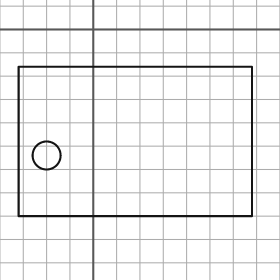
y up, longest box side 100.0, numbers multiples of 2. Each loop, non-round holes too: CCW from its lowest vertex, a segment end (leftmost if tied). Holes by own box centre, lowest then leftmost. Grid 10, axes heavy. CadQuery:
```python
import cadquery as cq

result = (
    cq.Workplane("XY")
    .moveTo(-32.0, -80.0)
    .lineTo(68.0, -80.0)
    .lineTo(68.0, -16.0)
    .lineTo(-32.0, -16.0)
    .close()
    .moveTo(-20.0, -54.0)
    .circle(6.0)
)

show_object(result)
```